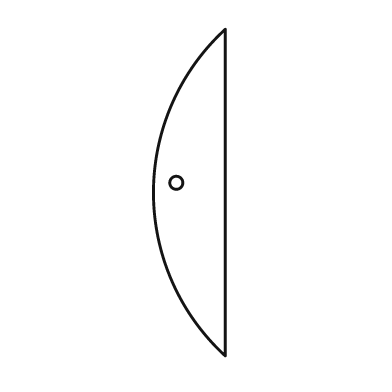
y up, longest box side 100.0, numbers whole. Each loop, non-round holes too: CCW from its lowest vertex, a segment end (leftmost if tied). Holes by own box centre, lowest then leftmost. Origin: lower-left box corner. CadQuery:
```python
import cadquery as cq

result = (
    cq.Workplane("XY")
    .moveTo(22.0, 0.0)
    .lineTo(22.0, 100.0)
    .threePointArc((0.0, 50.0), (22.0, 0.0))
    .close()
    .moveTo(7.0, 53.0)
    .circle(2.0)
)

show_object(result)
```